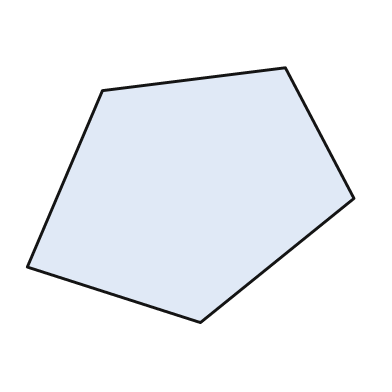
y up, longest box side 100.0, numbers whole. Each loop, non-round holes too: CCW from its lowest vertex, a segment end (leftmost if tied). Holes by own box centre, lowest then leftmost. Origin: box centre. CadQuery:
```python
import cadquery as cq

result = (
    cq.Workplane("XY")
    .moveTo(3.0, -39.0)
    .lineTo(50.0, -1.0)
    .lineTo(29.0, 39.0)
    .lineTo(-27.0, 32.0)
    .lineTo(-50.0, -22.0)
    .close()
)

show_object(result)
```